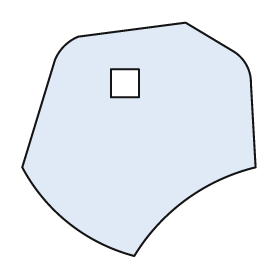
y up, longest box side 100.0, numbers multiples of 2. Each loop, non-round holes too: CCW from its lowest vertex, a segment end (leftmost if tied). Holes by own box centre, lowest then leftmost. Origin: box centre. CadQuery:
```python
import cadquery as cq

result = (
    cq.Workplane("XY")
    .moveTo(-2.0, -50.0)
    .threePointArc((20.0, -26.0), (50.0, -12.0))
    .lineTo(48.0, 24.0)
    .threePointArc((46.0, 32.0), (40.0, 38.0))
    .lineTo(20.0, 50.0)
    .lineTo(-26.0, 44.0)
    .threePointArc((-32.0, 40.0), (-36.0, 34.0))
    .lineTo(-50.0, -12.0)
    .threePointArc((-30.0, -36.0), (-2.0, -50.0))
    .close()
    .moveTo(-12.0, 18.0)
    .lineTo(0.0, 18.0)
    .lineTo(0.0, 30.0)
    .lineTo(-12.0, 30.0)
    .close()
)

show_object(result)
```